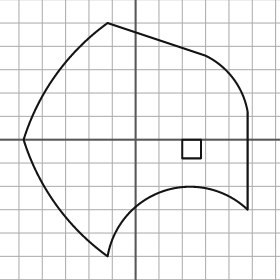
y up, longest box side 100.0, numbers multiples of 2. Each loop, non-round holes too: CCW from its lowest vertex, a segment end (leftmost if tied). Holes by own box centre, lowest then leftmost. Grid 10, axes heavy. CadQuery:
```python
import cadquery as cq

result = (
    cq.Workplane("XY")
    .moveTo(-12.0, -50.0)
    .threePointArc((12.0, -22.0), (48.0, -30.0))
    .lineTo(48.0, 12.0)
    .threePointArc((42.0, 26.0), (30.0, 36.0))
    .lineTo(-12.0, 50.0)
    .threePointArc((-34.0, 28.0), (-48.0, 0.0))
    .threePointArc((-34.0, -28.0), (-12.0, -50.0))
    .close()
    .moveTo(20.0, -8.0)
    .lineTo(28.0, -8.0)
    .lineTo(28.0, 0.0)
    .lineTo(20.0, 0.0)
    .close()
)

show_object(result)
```